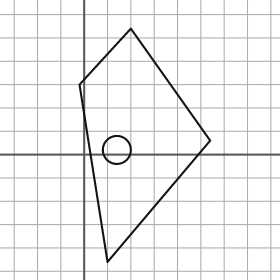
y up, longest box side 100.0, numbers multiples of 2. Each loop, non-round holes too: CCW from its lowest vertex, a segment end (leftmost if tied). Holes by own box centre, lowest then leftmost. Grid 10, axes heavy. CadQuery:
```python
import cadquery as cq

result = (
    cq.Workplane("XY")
    .moveTo(10.0, -46.0)
    .lineTo(54.0, 6.0)
    .lineTo(20.0, 54.0)
    .lineTo(-2.0, 30.0)
    .close()
    .moveTo(14.0, 2.0)
    .circle(6.0)
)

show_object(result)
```